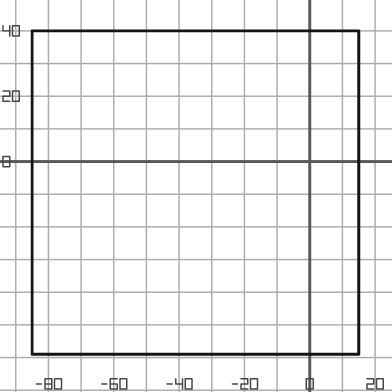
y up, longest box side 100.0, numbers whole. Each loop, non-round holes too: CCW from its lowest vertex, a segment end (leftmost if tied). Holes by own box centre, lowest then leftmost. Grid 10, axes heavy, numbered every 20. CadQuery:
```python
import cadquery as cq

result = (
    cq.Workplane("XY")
    .moveTo(-85.0, -59.0)
    .lineTo(15.0, -59.0)
    .lineTo(15.0, 40.0)
    .lineTo(-85.0, 40.0)
    .close()
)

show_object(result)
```